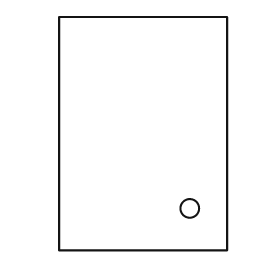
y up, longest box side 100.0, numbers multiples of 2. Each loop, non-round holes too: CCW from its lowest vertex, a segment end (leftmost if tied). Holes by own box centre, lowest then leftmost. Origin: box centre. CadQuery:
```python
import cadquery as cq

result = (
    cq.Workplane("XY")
    .moveTo(-36.0, -50.0)
    .lineTo(36.0, -50.0)
    .lineTo(36.0, 50.0)
    .lineTo(-36.0, 50.0)
    .close()
    .moveTo(20.0, -32.0)
    .circle(4.0)
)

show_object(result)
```